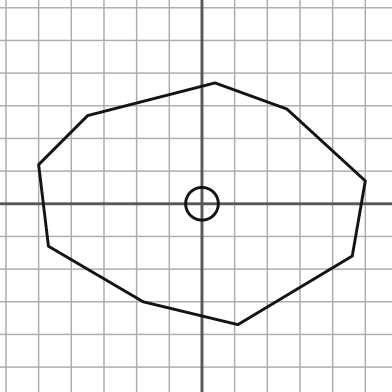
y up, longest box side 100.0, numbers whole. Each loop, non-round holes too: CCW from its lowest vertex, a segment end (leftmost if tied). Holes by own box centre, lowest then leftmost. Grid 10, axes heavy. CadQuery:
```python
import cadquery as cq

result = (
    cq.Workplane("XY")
    .moveTo(11.0, -37.0)
    .lineTo(46.0, -16.0)
    .lineTo(50.0, 7.0)
    .lineTo(26.0, 29.0)
    .lineTo(4.0, 37.0)
    .lineTo(-35.0, 27.0)
    .lineTo(-50.0, 12.0)
    .lineTo(-47.0, -13.0)
    .lineTo(-18.0, -30.0)
    .close()
    .moveTo(0.0, 0.0)
    .circle(5.0)
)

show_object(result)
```